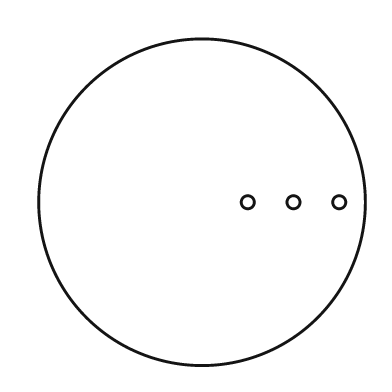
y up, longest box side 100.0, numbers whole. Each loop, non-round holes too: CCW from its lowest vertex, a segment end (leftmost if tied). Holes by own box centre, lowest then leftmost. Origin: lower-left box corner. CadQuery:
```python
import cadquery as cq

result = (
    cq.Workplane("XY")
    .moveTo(50.0, 50.0)
    .circle(50.0)
    .moveTo(64.0, 50.0)
    .circle(2.0)
    .moveTo(78.0, 50.0)
    .circle(2.0)
    .moveTo(92.0, 50.0)
    .circle(2.0)
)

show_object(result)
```